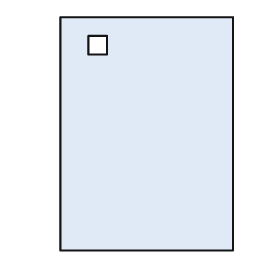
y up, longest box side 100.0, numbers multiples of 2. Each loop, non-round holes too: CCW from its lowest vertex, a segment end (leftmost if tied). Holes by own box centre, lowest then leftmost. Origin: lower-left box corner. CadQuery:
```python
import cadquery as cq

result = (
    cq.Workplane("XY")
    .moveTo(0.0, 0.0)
    .lineTo(74.0, 0.0)
    .lineTo(74.0, 100.0)
    .lineTo(0.0, 100.0)
    .close()
    .moveTo(12.0, 84.0)
    .lineTo(20.0, 84.0)
    .lineTo(20.0, 92.0)
    .lineTo(12.0, 92.0)
    .close()
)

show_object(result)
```